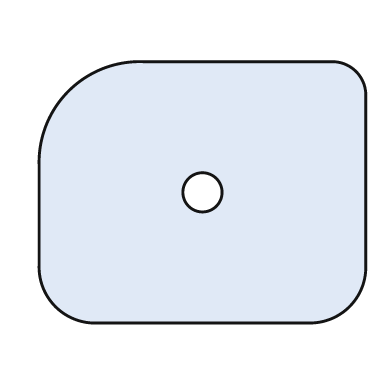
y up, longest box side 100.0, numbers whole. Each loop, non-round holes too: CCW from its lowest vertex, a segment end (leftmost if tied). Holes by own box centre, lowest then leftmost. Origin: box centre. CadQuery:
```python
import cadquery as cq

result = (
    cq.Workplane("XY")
    .moveTo(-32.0, -40.0)
    .lineTo(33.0, -40.0)
    .threePointArc((45.0, -35.0), (50.0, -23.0))
    .lineTo(50.0, 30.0)
    .threePointArc((47.0, 37.0), (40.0, 40.0))
    .lineTo(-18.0, 40.0)
    .threePointArc((-41.0, 31.0), (-50.0, 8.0))
    .lineTo(-50.0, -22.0)
    .threePointArc((-45.0, -35.0), (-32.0, -40.0))
    .close()
    .moveTo(0.0, 0.0)
    .circle(6.0)
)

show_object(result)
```